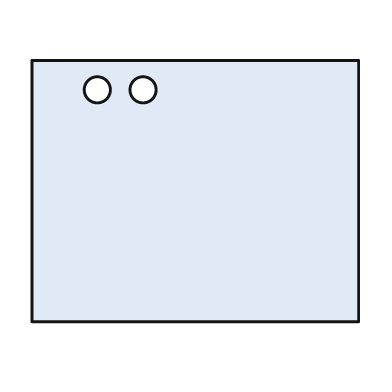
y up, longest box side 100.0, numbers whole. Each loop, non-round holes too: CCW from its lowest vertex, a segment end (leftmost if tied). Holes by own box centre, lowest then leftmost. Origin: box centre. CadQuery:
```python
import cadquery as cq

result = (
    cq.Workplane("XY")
    .moveTo(-50.0, -40.0)
    .lineTo(50.0, -40.0)
    .lineTo(50.0, 40.0)
    .lineTo(-50.0, 40.0)
    .close()
    .moveTo(-30.0, 31.0)
    .circle(4.0)
    .moveTo(-16.0, 31.0)
    .circle(4.0)
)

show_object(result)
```